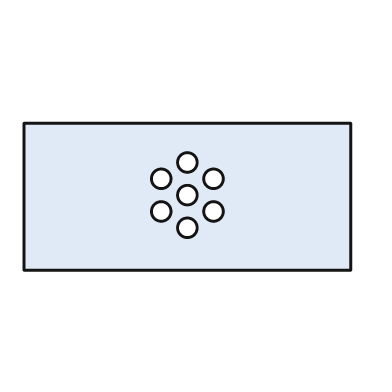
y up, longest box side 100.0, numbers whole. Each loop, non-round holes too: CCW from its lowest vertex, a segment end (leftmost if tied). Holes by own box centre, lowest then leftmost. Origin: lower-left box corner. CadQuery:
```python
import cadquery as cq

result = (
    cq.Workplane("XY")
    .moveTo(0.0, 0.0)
    .lineTo(100.0, 0.0)
    .lineTo(100.0, 45.0)
    .lineTo(0.0, 45.0)
    .close()
    .moveTo(50.0, 13.0)
    .circle(3.0)
    .moveTo(42.0, 18.0)
    .circle(3.0)
    .moveTo(58.0, 18.0)
    .circle(3.0)
    .moveTo(50.0, 23.0)
    .circle(3.0)
    .moveTo(42.0, 28.0)
    .circle(3.0)
    .moveTo(58.0, 28.0)
    .circle(3.0)
    .moveTo(50.0, 33.0)
    .circle(3.0)
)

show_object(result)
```